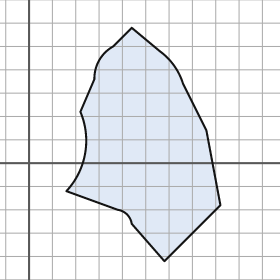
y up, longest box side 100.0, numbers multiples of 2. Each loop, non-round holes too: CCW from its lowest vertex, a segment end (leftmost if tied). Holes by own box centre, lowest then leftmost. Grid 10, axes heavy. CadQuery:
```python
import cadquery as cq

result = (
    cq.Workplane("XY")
    .moveTo(58.0, -42.0)
    .lineTo(82.0, -18.0)
    .lineTo(76.0, 14.0)
    .lineTo(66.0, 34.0)
    .threePointArc((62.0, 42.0), (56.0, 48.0))
    .lineTo(44.0, 58.0)
    .lineTo(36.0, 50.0)
    .threePointArc((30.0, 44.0), (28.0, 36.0))
    .lineTo(22.0, 22.0)
    .threePointArc((24.0, 4.0), (16.0, -12.0))
    .lineTo(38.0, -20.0)
    .threePointArc((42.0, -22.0), (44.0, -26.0))
    .close()
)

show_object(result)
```